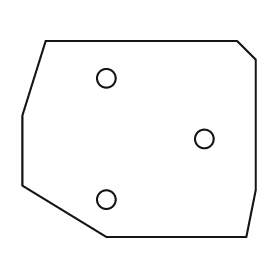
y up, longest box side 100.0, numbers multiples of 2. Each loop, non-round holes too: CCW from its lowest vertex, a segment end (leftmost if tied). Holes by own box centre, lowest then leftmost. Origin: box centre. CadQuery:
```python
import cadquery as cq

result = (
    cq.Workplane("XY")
    .moveTo(-14.0, -42.0)
    .lineTo(46.0, -42.0)
    .lineTo(50.0, -22.0)
    .lineTo(50.0, 34.0)
    .lineTo(42.0, 42.0)
    .lineTo(-40.0, 42.0)
    .lineTo(-50.0, 10.0)
    .lineTo(-50.0, -20.0)
    .close()
    .moveTo(-14.0, -26.0)
    .circle(4.0)
    .moveTo(28.0, 0.0)
    .circle(4.0)
    .moveTo(-14.0, 26.0)
    .circle(4.0)
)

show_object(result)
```